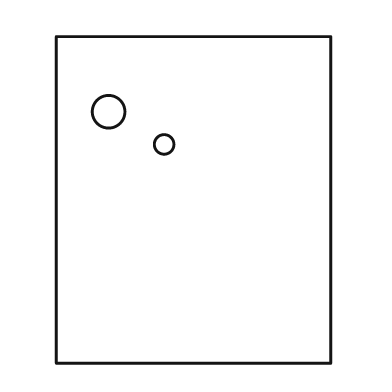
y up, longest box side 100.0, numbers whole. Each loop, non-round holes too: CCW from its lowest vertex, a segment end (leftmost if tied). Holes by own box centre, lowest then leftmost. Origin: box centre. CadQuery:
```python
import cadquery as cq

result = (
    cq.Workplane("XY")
    .moveTo(-42.0, -50.0)
    .lineTo(42.0, -50.0)
    .lineTo(42.0, 50.0)
    .lineTo(-42.0, 50.0)
    .close()
    .moveTo(-9.0, 17.0)
    .circle(3.0)
    .moveTo(-26.0, 27.0)
    .circle(5.0)
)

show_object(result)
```